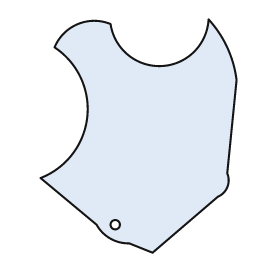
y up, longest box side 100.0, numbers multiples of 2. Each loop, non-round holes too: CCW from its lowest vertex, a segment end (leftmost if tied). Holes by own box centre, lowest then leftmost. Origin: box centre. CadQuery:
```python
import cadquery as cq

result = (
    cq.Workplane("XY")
    .moveTo(6.0, -50.0)
    .lineTo(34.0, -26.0)
    .threePointArc((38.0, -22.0), (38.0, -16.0))
    .lineTo(42.0, 24.0)
    .threePointArc((38.0, 38.0), (30.0, 50.0))
    .threePointArc((10.0, 30.0), (-12.0, 48.0))
    .threePointArc((-26.0, 48.0), (-36.0, 38.0))
    .threePointArc((-22.0, 8.0), (-42.0, -18.0))
    .lineTo(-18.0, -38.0)
    .threePointArc((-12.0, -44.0), (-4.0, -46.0))
    .close()
    .moveTo(-10.0, -38.0)
    .circle(2.0)
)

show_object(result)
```